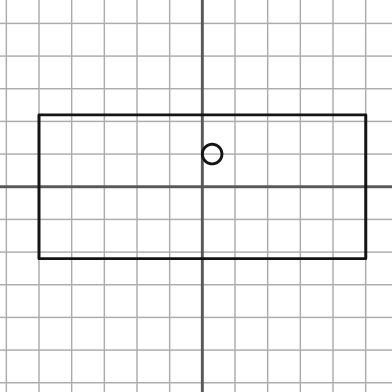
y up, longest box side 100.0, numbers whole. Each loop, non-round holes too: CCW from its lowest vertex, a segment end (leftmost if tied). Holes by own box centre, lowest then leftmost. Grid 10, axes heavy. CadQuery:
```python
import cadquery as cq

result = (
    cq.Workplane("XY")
    .moveTo(-50.0, -22.0)
    .lineTo(50.0, -22.0)
    .lineTo(50.0, 22.0)
    .lineTo(-50.0, 22.0)
    .close()
    .moveTo(3.0, 10.0)
    .circle(3.0)
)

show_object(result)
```